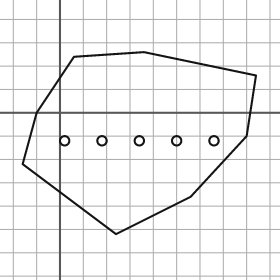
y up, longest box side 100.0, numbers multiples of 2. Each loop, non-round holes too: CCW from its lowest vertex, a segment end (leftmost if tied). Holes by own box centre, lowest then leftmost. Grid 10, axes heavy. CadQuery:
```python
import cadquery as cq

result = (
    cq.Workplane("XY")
    .moveTo(24.0, -52.0)
    .lineTo(56.0, -36.0)
    .lineTo(80.0, -10.0)
    .lineTo(84.0, 16.0)
    .lineTo(36.0, 26.0)
    .lineTo(6.0, 24.0)
    .lineTo(-10.0, 0.0)
    .lineTo(-16.0, -22.0)
    .close()
    .moveTo(2.0, -12.0)
    .circle(2.0)
    .moveTo(18.0, -12.0)
    .circle(2.0)
    .moveTo(34.0, -12.0)
    .circle(2.0)
    .moveTo(50.0, -12.0)
    .circle(2.0)
    .moveTo(66.0, -12.0)
    .circle(2.0)
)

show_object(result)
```